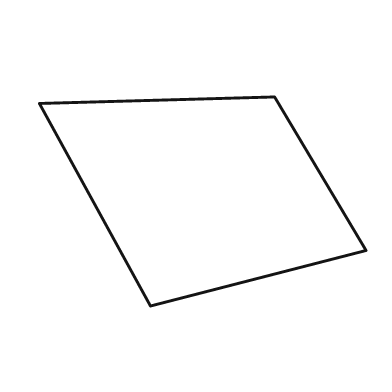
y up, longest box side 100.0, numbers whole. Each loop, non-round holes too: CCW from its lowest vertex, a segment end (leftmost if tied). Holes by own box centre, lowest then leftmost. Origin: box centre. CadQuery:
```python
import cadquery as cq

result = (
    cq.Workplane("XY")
    .moveTo(-16.0, -32.0)
    .lineTo(50.0, -15.0)
    .lineTo(22.0, 32.0)
    .lineTo(-50.0, 30.0)
    .close()
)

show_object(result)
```